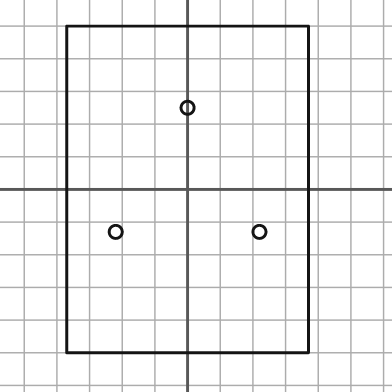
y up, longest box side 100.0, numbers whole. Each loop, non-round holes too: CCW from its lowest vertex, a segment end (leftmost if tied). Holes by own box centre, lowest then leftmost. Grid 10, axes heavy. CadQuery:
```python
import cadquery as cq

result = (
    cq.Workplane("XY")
    .moveTo(-37.0, -50.0)
    .lineTo(37.0, -50.0)
    .lineTo(37.0, 50.0)
    .lineTo(-37.0, 50.0)
    .close()
    .moveTo(-22.0, -13.0)
    .circle(2.0)
    .moveTo(22.0, -13.0)
    .circle(2.0)
    .moveTo(0.0, 25.0)
    .circle(2.0)
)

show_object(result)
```